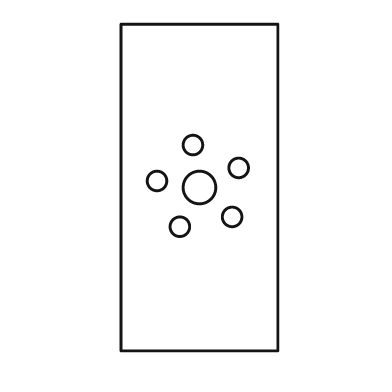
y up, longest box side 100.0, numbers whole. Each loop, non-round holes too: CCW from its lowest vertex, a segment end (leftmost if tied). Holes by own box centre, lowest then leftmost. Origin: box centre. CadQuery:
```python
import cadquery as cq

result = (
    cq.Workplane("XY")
    .moveTo(-24.0, -50.0)
    .lineTo(24.0, -50.0)
    .lineTo(24.0, 50.0)
    .lineTo(-24.0, 50.0)
    .close()
    .moveTo(-6.0, -12.0)
    .circle(3.0)
    .moveTo(10.0, -9.0)
    .circle(3.0)
    .moveTo(0.0, 0.0)
    .circle(5.0)
    .moveTo(-13.0, 2.0)
    .circle(3.0)
    .moveTo(12.0, 6.0)
    .circle(3.0)
    .moveTo(-2.0, 13.0)
    .circle(3.0)
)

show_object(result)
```